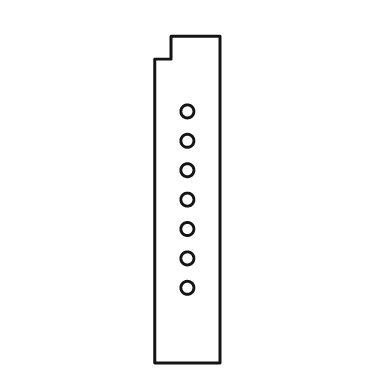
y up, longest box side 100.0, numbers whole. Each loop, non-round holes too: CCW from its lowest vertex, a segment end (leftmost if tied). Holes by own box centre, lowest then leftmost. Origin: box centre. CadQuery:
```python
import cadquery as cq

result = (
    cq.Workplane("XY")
    .moveTo(-10.0, -50.0)
    .lineTo(10.0, -50.0)
    .lineTo(10.0, 50.0)
    .lineTo(-5.0, 50.0)
    .lineTo(-5.0, 43.0)
    .lineTo(-10.0, 43.0)
    .close()
    .moveTo(0.0, -27.0)
    .circle(2.0)
    .moveTo(0.0, -18.0)
    .circle(2.0)
    .moveTo(0.0, -9.0)
    .circle(2.0)
    .moveTo(0.0, 0.0)
    .circle(2.0)
    .moveTo(0.0, 9.0)
    .circle(2.0)
    .moveTo(0.0, 18.0)
    .circle(2.0)
    .moveTo(0.0, 27.0)
    .circle(2.0)
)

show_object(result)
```